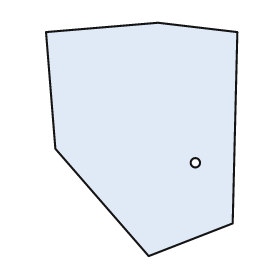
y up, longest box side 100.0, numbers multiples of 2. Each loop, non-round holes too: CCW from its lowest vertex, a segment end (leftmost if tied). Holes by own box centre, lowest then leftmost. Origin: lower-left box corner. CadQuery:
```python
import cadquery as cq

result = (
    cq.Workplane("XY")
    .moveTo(44.0, 0.0)
    .lineTo(80.0, 14.0)
    .lineTo(82.0, 96.0)
    .lineTo(48.0, 100.0)
    .lineTo(0.0, 96.0)
    .lineTo(4.0, 46.0)
    .close()
    .moveTo(64.0, 40.0)
    .circle(2.0)
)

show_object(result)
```